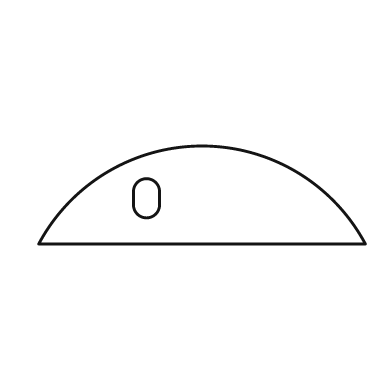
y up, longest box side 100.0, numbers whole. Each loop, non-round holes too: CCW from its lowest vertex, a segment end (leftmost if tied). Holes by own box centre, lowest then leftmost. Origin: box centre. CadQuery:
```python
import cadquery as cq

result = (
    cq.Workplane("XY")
    .moveTo(-50.0, -15.0)
    .lineTo(50.0, -15.0)
    .threePointArc((0.0, 15.0), (-50.0, -15.0))
    .close()
    .moveTo(-21.0, -3.0)
    .threePointArc((-17.0, -7.0), (-13.0, -3.0))
    .lineTo(-13.0, 1.0)
    .threePointArc((-17.0, 5.0), (-21.0, 1.0))
    .close()
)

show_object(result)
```